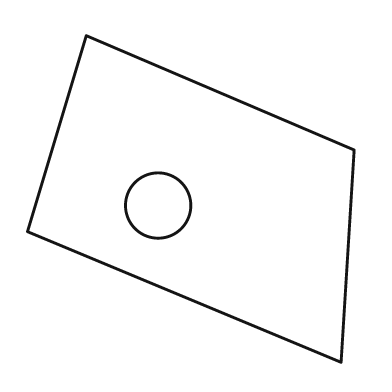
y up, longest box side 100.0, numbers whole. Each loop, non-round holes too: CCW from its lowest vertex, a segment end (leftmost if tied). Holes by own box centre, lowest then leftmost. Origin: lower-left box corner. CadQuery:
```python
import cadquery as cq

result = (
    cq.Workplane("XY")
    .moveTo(96.0, 0.0)
    .lineTo(100.0, 65.0)
    .lineTo(18.0, 100.0)
    .lineTo(0.0, 40.0)
    .close()
    .moveTo(40.0, 48.0)
    .circle(10.0)
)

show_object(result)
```